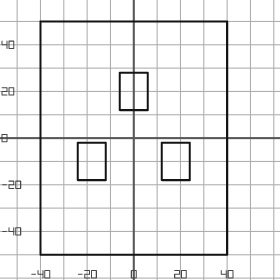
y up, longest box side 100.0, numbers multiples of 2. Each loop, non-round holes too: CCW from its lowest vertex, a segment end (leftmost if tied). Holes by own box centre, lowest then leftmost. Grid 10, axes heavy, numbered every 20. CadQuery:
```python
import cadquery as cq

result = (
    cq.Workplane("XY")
    .moveTo(-40.0, -50.0)
    .lineTo(40.0, -50.0)
    .lineTo(40.0, 50.0)
    .lineTo(-40.0, 50.0)
    .close()
    .moveTo(-24.0, -18.0)
    .lineTo(-12.0, -18.0)
    .lineTo(-12.0, -2.0)
    .lineTo(-24.0, -2.0)
    .close()
    .moveTo(12.0, -18.0)
    .lineTo(24.0, -18.0)
    .lineTo(24.0, -2.0)
    .lineTo(12.0, -2.0)
    .close()
    .moveTo(-6.0, 12.0)
    .lineTo(6.0, 12.0)
    .lineTo(6.0, 28.0)
    .lineTo(-6.0, 28.0)
    .close()
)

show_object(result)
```